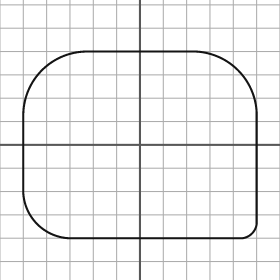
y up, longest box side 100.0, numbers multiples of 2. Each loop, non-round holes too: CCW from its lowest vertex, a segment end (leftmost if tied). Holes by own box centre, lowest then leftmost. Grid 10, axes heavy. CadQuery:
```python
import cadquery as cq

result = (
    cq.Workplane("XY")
    .moveTo(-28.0, -40.0)
    .lineTo(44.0, -40.0)
    .threePointArc((48.0, -38.0), (50.0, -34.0))
    .lineTo(50.0, 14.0)
    .threePointArc((42.0, 32.0), (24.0, 40.0))
    .lineTo(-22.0, 40.0)
    .threePointArc((-42.0, 32.0), (-50.0, 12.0))
    .lineTo(-50.0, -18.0)
    .threePointArc((-44.0, -34.0), (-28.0, -40.0))
    .close()
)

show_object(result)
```